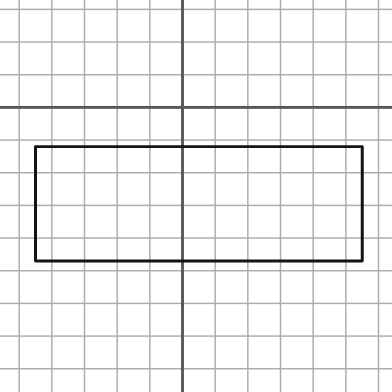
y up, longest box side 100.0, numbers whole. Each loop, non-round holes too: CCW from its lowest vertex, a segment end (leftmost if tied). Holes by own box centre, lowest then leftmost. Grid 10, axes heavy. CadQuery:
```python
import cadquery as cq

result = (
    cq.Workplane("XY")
    .moveTo(-45.0, -47.0)
    .lineTo(55.0, -47.0)
    .lineTo(55.0, -12.0)
    .lineTo(-45.0, -12.0)
    .close()
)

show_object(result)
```